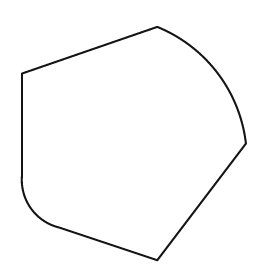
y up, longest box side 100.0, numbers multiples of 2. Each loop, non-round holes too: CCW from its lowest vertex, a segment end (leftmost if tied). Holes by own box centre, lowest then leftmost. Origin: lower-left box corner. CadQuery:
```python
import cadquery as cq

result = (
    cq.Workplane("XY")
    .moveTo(58.0, 0.0)
    .lineTo(96.0, 50.0)
    .threePointArc((84.0, 80.0), (58.0, 100.0))
    .lineTo(0.0, 80.0)
    .lineTo(0.0, 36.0)
    .threePointArc((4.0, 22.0), (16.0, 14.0))
    .close()
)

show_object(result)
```